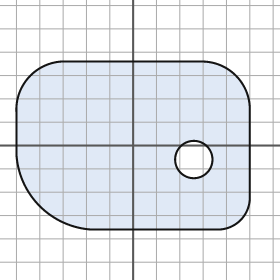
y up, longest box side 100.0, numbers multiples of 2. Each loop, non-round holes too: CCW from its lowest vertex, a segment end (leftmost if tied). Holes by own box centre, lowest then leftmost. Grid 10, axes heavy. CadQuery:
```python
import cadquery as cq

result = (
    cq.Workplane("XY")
    .moveTo(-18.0, -36.0)
    .lineTo(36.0, -36.0)
    .threePointArc((46.0, -32.0), (50.0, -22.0))
    .lineTo(50.0, 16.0)
    .threePointArc((44.0, 30.0), (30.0, 36.0))
    .lineTo(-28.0, 36.0)
    .threePointArc((-44.0, 30.0), (-50.0, 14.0))
    .lineTo(-50.0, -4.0)
    .threePointArc((-40.0, -26.0), (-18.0, -36.0))
    .close()
    .moveTo(26.0, -6.0)
    .circle(8.0)
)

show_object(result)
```